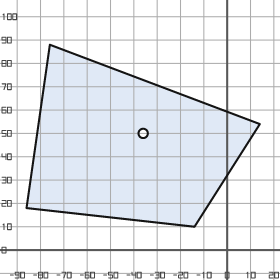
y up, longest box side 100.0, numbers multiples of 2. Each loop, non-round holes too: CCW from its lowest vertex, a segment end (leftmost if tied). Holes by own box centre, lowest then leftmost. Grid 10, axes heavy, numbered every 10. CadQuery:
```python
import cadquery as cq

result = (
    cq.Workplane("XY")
    .moveTo(-14.0, 10.0)
    .lineTo(14.0, 54.0)
    .lineTo(-76.0, 88.0)
    .lineTo(-86.0, 18.0)
    .close()
    .moveTo(-36.0, 50.0)
    .circle(2.0)
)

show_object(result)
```